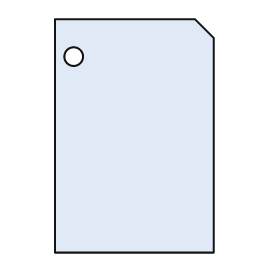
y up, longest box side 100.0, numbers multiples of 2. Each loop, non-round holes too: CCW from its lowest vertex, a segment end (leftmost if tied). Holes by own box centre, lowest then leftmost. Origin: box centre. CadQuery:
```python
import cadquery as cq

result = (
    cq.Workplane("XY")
    .moveTo(-34.0, -50.0)
    .lineTo(34.0, -50.0)
    .lineTo(34.0, 42.0)
    .lineTo(26.0, 50.0)
    .lineTo(-34.0, 50.0)
    .close()
    .moveTo(-26.0, 34.0)
    .circle(4.0)
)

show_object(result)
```